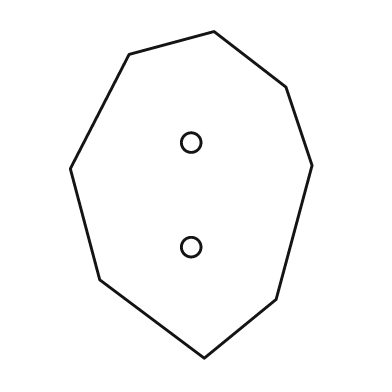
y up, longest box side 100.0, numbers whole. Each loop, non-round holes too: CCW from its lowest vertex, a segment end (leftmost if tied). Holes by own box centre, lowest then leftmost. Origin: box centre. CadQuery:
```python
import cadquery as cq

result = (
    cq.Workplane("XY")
    .moveTo(4.0, -50.0)
    .lineTo(26.0, -32.0)
    .lineTo(37.0, 9.0)
    .lineTo(29.0, 33.0)
    .lineTo(7.0, 50.0)
    .lineTo(-19.0, 43.0)
    .lineTo(-37.0, 8.0)
    .lineTo(-28.0, -26.0)
    .close()
    .moveTo(0.0, -16.0)
    .circle(3.0)
    .moveTo(0.0, 16.0)
    .circle(3.0)
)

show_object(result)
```